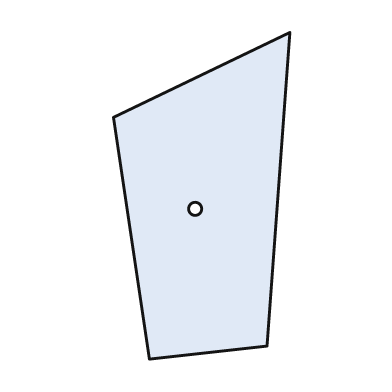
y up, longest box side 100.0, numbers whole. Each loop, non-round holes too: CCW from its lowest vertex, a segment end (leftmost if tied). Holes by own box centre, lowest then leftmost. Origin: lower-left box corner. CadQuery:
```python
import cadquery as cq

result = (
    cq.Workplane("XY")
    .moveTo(11.0, 0.0)
    .lineTo(47.0, 4.0)
    .lineTo(54.0, 100.0)
    .lineTo(0.0, 74.0)
    .close()
    .moveTo(25.0, 46.0)
    .circle(2.0)
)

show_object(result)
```